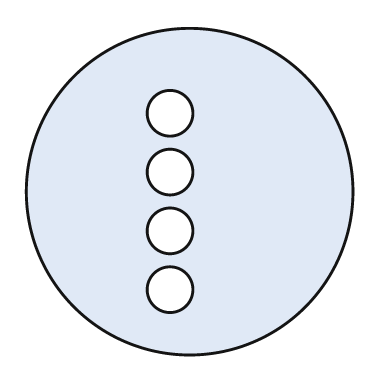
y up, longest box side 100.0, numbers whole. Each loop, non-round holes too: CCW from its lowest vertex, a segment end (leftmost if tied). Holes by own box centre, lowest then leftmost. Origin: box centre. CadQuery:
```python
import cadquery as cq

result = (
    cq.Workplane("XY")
    .moveTo(0.0, 0.0)
    .circle(50.0)
    .moveTo(-6.0, -30.0)
    .circle(7.0)
    .moveTo(-6.0, -12.0)
    .circle(7.0)
    .moveTo(-6.0, 6.0)
    .circle(7.0)
    .moveTo(-6.0, 24.0)
    .circle(7.0)
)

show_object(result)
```